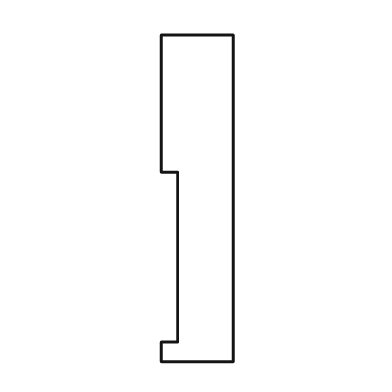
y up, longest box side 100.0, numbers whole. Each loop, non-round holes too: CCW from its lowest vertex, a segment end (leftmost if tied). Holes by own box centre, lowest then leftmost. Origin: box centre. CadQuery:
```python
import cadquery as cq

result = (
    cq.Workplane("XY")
    .moveTo(-11.0, -50.0)
    .lineTo(11.0, -50.0)
    .lineTo(11.0, 50.0)
    .lineTo(-11.0, 50.0)
    .lineTo(-11.0, 8.0)
    .lineTo(-6.0, 8.0)
    .lineTo(-6.0, -44.0)
    .lineTo(-11.0, -44.0)
    .close()
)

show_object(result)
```